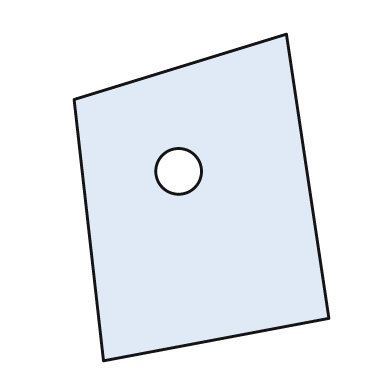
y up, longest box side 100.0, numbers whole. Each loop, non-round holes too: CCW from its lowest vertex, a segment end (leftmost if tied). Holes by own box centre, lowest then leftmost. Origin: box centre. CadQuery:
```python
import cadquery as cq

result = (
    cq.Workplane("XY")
    .moveTo(-30.0, -50.0)
    .lineTo(39.0, -37.0)
    .lineTo(26.0, 50.0)
    .lineTo(-39.0, 30.0)
    .close()
    .moveTo(-7.0, 8.0)
    .circle(7.0)
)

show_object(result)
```